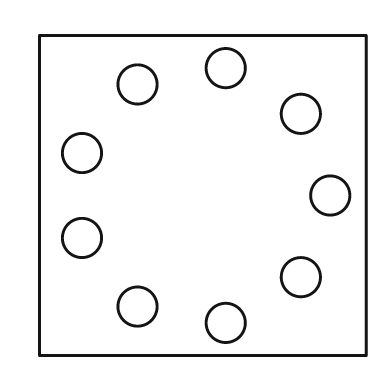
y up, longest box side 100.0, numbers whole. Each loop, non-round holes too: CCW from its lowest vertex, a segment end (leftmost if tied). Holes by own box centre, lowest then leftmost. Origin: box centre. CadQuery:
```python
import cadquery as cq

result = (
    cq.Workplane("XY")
    .moveTo(-50.0, -49.0)
    .lineTo(50.0, -49.0)
    .lineTo(50.0, 49.0)
    .lineTo(-50.0, 49.0)
    .close()
    .moveTo(7.0, -39.0)
    .circle(6.0)
    .moveTo(-20.0, -34.0)
    .circle(6.0)
    .moveTo(30.0, -25.0)
    .circle(6.0)
    .moveTo(-37.0, -13.0)
    .circle(6.0)
    .moveTo(39.0, 0.0)
    .circle(6.0)
    .moveTo(-37.0, 13.0)
    .circle(6.0)
    .moveTo(30.0, 25.0)
    .circle(6.0)
    .moveTo(-20.0, 34.0)
    .circle(6.0)
    .moveTo(7.0, 39.0)
    .circle(6.0)
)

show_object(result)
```